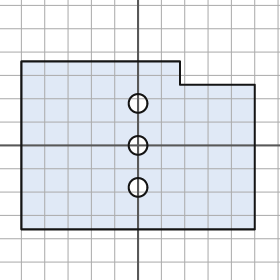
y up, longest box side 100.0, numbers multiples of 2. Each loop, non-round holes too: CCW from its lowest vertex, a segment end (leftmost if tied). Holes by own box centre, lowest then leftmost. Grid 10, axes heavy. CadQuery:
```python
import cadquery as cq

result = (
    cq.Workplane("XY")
    .moveTo(-50.0, -36.0)
    .lineTo(50.0, -36.0)
    .lineTo(50.0, 26.0)
    .lineTo(18.0, 26.0)
    .lineTo(18.0, 36.0)
    .lineTo(-50.0, 36.0)
    .close()
    .moveTo(0.0, -18.0)
    .circle(4.0)
    .moveTo(0.0, 0.0)
    .circle(4.0)
    .moveTo(0.0, 18.0)
    .circle(4.0)
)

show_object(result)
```